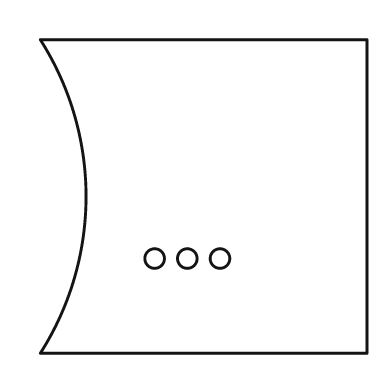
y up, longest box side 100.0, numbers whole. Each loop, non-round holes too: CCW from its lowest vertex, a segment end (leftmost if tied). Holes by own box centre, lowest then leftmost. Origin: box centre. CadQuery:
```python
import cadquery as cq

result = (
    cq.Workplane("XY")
    .moveTo(-50.0, -48.0)
    .lineTo(50.0, -48.0)
    .lineTo(50.0, 48.0)
    .lineTo(-50.0, 48.0)
    .threePointArc((-36.0, 0.0), (-50.0, -48.0))
    .close()
    .moveTo(-15.0, -19.0)
    .circle(3.0)
    .moveTo(-5.0, -19.0)
    .circle(3.0)
    .moveTo(5.0, -19.0)
    .circle(3.0)
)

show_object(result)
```